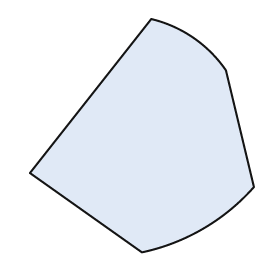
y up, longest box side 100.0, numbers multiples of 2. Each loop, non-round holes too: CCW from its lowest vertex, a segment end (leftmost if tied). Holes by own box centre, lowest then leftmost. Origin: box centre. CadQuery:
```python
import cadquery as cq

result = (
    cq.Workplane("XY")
    .moveTo(0.0, -50.0)
    .threePointArc((26.0, -40.0), (48.0, -22.0))
    .lineTo(36.0, 28.0)
    .threePointArc((22.0, 42.0), (4.0, 50.0))
    .lineTo(-48.0, -16.0)
    .close()
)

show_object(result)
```